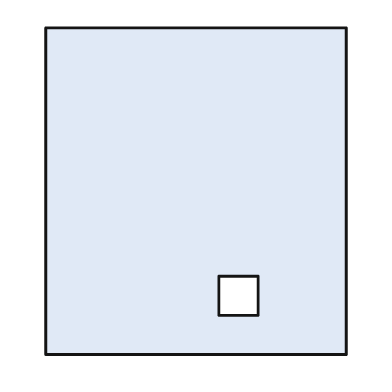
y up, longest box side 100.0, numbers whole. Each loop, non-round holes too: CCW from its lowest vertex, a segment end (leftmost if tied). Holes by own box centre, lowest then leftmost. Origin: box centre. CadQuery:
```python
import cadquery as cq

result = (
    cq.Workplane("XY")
    .moveTo(-46.0, -50.0)
    .lineTo(46.0, -50.0)
    .lineTo(46.0, 50.0)
    .lineTo(-46.0, 50.0)
    .close()
    .moveTo(7.0, -38.0)
    .lineTo(19.0, -38.0)
    .lineTo(19.0, -26.0)
    .lineTo(7.0, -26.0)
    .close()
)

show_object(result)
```